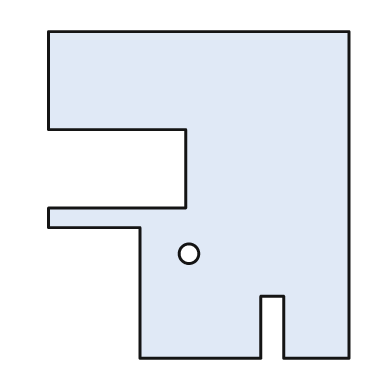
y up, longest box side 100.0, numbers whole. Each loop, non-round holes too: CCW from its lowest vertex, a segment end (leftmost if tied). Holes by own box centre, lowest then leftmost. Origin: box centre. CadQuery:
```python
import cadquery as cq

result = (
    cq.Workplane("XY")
    .moveTo(-18.0, -50.0)
    .lineTo(19.0, -50.0)
    .lineTo(19.0, -31.0)
    .lineTo(26.0, -31.0)
    .lineTo(26.0, -50.0)
    .lineTo(46.0, -50.0)
    .lineTo(46.0, 50.0)
    .lineTo(-46.0, 50.0)
    .lineTo(-46.0, 20.0)
    .lineTo(-4.0, 20.0)
    .lineTo(-4.0, -4.0)
    .lineTo(-46.0, -4.0)
    .lineTo(-46.0, -10.0)
    .lineTo(-18.0, -10.0)
    .close()
    .moveTo(-3.0, -18.0)
    .circle(3.0)
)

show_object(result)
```